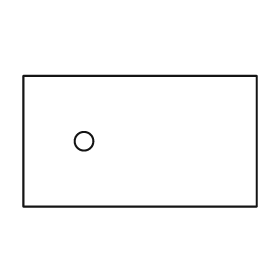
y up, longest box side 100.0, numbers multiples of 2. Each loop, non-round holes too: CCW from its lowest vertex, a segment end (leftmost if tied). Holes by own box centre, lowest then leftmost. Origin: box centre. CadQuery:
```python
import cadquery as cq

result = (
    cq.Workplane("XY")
    .moveTo(-50.0, -28.0)
    .lineTo(50.0, -28.0)
    .lineTo(50.0, 28.0)
    .lineTo(-50.0, 28.0)
    .close()
    .moveTo(-24.0, 0.0)
    .circle(4.0)
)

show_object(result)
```